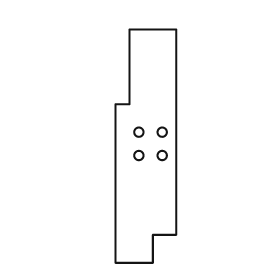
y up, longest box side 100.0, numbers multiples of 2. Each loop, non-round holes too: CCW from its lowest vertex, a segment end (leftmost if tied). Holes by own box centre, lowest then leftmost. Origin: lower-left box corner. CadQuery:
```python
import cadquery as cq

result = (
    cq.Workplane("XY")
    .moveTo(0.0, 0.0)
    .lineTo(16.0, 0.0)
    .lineTo(16.0, 12.0)
    .lineTo(26.0, 12.0)
    .lineTo(26.0, 100.0)
    .lineTo(6.0, 100.0)
    .lineTo(6.0, 68.0)
    .lineTo(0.0, 68.0)
    .close()
    .moveTo(10.0, 46.0)
    .circle(2.0)
    .moveTo(20.0, 46.0)
    .circle(2.0)
    .moveTo(10.0, 56.0)
    .circle(2.0)
    .moveTo(20.0, 56.0)
    .circle(2.0)
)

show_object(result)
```